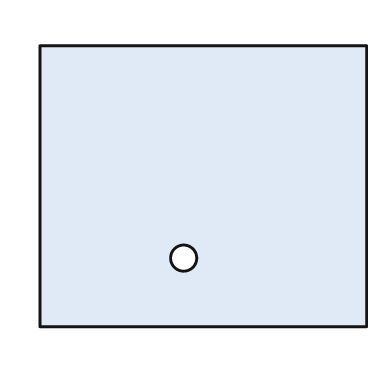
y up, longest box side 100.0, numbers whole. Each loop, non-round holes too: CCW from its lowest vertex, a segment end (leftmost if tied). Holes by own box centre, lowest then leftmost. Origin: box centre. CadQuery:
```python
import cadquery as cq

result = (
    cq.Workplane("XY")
    .moveTo(-50.0, -43.0)
    .lineTo(50.0, -43.0)
    .lineTo(50.0, 43.0)
    .lineTo(-50.0, 43.0)
    .close()
    .moveTo(-6.0, -22.0)
    .circle(4.0)
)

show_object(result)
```